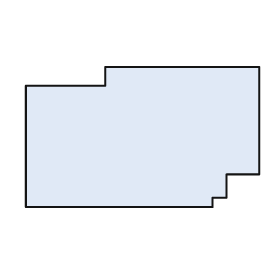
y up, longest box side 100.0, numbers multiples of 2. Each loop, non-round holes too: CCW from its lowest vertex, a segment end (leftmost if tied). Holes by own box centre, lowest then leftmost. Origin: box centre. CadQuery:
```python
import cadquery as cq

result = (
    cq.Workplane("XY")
    .moveTo(-50.0, -30.0)
    .lineTo(30.0, -30.0)
    .lineTo(30.0, -26.0)
    .lineTo(36.0, -26.0)
    .lineTo(36.0, -16.0)
    .lineTo(50.0, -16.0)
    .lineTo(50.0, 30.0)
    .lineTo(-16.0, 30.0)
    .lineTo(-16.0, 22.0)
    .lineTo(-50.0, 22.0)
    .close()
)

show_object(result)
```